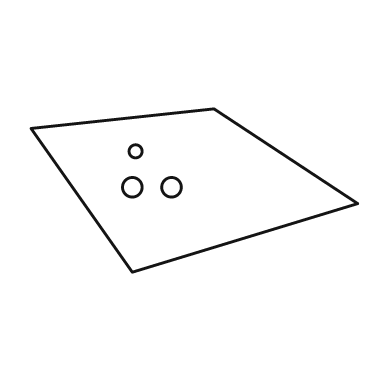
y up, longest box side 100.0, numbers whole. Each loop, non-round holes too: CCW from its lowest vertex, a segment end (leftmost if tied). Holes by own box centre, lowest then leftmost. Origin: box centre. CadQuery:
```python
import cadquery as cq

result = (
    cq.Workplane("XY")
    .moveTo(-19.0, -25.0)
    .lineTo(50.0, -4.0)
    .lineTo(6.0, 25.0)
    .lineTo(-50.0, 19.0)
    .close()
    .moveTo(-19.0, 1.0)
    .circle(3.0)
    .moveTo(-7.0, 1.0)
    .circle(3.0)
    .moveTo(-18.0, 12.0)
    .circle(2.0)
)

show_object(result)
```